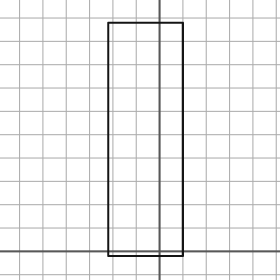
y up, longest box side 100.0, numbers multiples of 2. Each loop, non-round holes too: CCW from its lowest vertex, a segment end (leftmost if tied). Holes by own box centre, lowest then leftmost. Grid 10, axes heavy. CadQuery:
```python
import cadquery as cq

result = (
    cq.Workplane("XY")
    .moveTo(-22.0, -2.0)
    .lineTo(10.0, -2.0)
    .lineTo(10.0, 98.0)
    .lineTo(-22.0, 98.0)
    .close()
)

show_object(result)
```